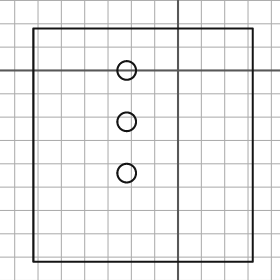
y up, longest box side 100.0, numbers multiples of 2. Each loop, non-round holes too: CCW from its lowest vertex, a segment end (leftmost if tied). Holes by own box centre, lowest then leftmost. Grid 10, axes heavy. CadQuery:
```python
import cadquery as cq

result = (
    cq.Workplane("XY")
    .moveTo(-62.0, -82.0)
    .lineTo(32.0, -82.0)
    .lineTo(32.0, 18.0)
    .lineTo(-62.0, 18.0)
    .close()
    .moveTo(-22.0, -44.0)
    .circle(4.0)
    .moveTo(-22.0, -22.0)
    .circle(4.0)
    .moveTo(-22.0, 0.0)
    .circle(4.0)
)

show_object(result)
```